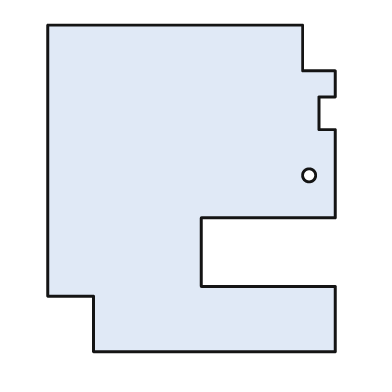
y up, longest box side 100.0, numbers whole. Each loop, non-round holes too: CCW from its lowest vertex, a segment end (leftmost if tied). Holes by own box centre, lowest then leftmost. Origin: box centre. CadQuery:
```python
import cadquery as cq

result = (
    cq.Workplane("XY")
    .moveTo(-30.0, -50.0)
    .lineTo(44.0, -50.0)
    .lineTo(44.0, -30.0)
    .lineTo(3.0, -30.0)
    .lineTo(3.0, -9.0)
    .lineTo(44.0, -9.0)
    .lineTo(44.0, 18.0)
    .lineTo(39.0, 18.0)
    .lineTo(39.0, 28.0)
    .lineTo(44.0, 28.0)
    .lineTo(44.0, 36.0)
    .lineTo(34.0, 36.0)
    .lineTo(34.0, 50.0)
    .lineTo(-44.0, 50.0)
    .lineTo(-44.0, -33.0)
    .lineTo(-30.0, -33.0)
    .close()
    .moveTo(36.0, 4.0)
    .circle(2.0)
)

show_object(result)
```